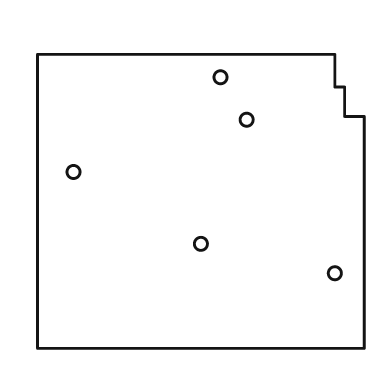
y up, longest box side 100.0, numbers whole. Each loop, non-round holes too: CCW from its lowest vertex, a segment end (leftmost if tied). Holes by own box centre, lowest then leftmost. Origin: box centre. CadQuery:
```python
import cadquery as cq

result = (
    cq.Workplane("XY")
    .moveTo(-50.0, -45.0)
    .lineTo(50.0, -45.0)
    .lineTo(50.0, 26.0)
    .lineTo(44.0, 26.0)
    .lineTo(44.0, 35.0)
    .lineTo(41.0, 35.0)
    .lineTo(41.0, 45.0)
    .lineTo(-50.0, 45.0)
    .close()
    .moveTo(41.0, -22.0)
    .circle(2.0)
    .moveTo(0.0, -13.0)
    .circle(2.0)
    .moveTo(-39.0, 9.0)
    .circle(2.0)
    .moveTo(14.0, 25.0)
    .circle(2.0)
    .moveTo(6.0, 38.0)
    .circle(2.0)
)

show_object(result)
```